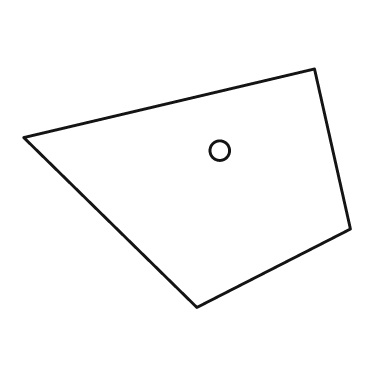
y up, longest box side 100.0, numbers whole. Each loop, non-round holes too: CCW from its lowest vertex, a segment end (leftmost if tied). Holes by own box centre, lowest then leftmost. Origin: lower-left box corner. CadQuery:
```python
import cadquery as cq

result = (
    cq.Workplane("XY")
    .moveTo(53.0, 0.0)
    .lineTo(100.0, 24.0)
    .lineTo(89.0, 73.0)
    .lineTo(0.0, 52.0)
    .close()
    .moveTo(60.0, 48.0)
    .circle(3.0)
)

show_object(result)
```